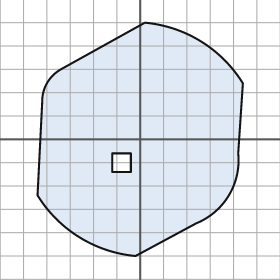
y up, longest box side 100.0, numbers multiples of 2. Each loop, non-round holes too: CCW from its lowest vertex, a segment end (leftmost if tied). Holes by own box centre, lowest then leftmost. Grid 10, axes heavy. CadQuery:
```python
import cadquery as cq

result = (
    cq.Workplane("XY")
    .moveTo(-2.0, -50.0)
    .lineTo(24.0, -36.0)
    .threePointArc((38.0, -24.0), (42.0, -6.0))
    .lineTo(44.0, 24.0)
    .threePointArc((26.0, 42.0), (2.0, 50.0))
    .lineTo(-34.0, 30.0)
    .threePointArc((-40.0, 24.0), (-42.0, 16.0))
    .lineTo(-44.0, -24.0)
    .threePointArc((-26.0, -42.0), (-2.0, -50.0))
    .close()
    .moveTo(-12.0, -14.0)
    .lineTo(-4.0, -14.0)
    .lineTo(-4.0, -6.0)
    .lineTo(-12.0, -6.0)
    .close()
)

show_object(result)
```